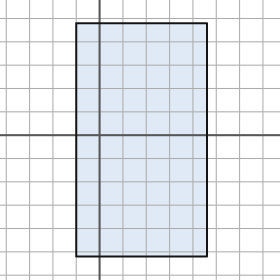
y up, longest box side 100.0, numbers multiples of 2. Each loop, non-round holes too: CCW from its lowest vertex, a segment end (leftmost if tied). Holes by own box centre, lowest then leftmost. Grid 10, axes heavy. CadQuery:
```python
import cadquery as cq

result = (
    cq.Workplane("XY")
    .moveTo(-10.0, -52.0)
    .lineTo(46.0, -52.0)
    .lineTo(46.0, 48.0)
    .lineTo(-10.0, 48.0)
    .close()
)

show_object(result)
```